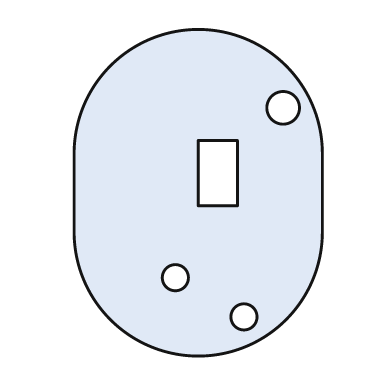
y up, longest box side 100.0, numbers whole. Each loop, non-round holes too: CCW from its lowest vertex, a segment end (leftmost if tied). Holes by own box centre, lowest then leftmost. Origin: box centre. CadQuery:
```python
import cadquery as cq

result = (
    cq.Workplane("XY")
    .moveTo(-38.0, -12.0)
    .threePointArc((0.0, -50.0), (38.0, -12.0))
    .lineTo(38.0, 12.0)
    .threePointArc((0.0, 50.0), (-38.0, 12.0))
    .close()
    .moveTo(14.0, -38.0)
    .circle(4.0)
    .moveTo(-7.0, -26.0)
    .circle(4.0)
    .moveTo(0.0, -4.0)
    .lineTo(12.0, -4.0)
    .lineTo(12.0, 16.0)
    .lineTo(0.0, 16.0)
    .close()
    .moveTo(26.0, 26.0)
    .circle(5.0)
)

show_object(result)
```